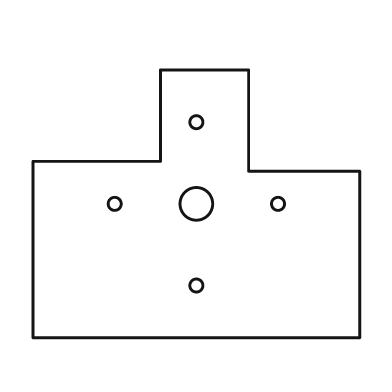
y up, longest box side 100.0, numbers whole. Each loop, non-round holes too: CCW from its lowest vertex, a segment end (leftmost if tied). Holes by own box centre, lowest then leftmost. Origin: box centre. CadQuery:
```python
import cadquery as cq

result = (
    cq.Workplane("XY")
    .moveTo(-50.0, -41.0)
    .lineTo(50.0, -41.0)
    .lineTo(50.0, 10.0)
    .lineTo(16.0, 10.0)
    .lineTo(16.0, 41.0)
    .lineTo(-11.0, 41.0)
    .lineTo(-11.0, 13.0)
    .lineTo(-50.0, 13.0)
    .close()
    .moveTo(0.0, -25.0)
    .circle(2.0)
    .moveTo(-25.0, 0.0)
    .circle(2.0)
    .moveTo(0.0, 0.0)
    .circle(5.0)
    .moveTo(25.0, 0.0)
    .circle(2.0)
    .moveTo(0.0, 25.0)
    .circle(2.0)
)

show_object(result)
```